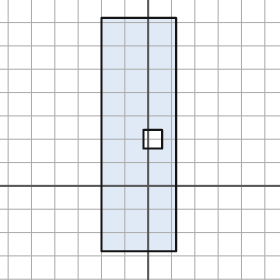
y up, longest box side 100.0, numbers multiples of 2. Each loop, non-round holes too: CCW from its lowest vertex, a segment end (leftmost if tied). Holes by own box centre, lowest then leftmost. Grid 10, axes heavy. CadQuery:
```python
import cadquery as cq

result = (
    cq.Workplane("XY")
    .moveTo(-20.0, -28.0)
    .lineTo(12.0, -28.0)
    .lineTo(12.0, 72.0)
    .lineTo(-20.0, 72.0)
    .close()
    .moveTo(-2.0, 16.0)
    .lineTo(6.0, 16.0)
    .lineTo(6.0, 24.0)
    .lineTo(-2.0, 24.0)
    .close()
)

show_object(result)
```